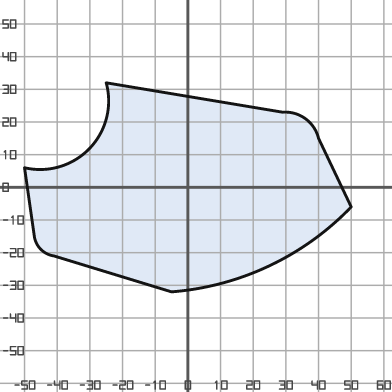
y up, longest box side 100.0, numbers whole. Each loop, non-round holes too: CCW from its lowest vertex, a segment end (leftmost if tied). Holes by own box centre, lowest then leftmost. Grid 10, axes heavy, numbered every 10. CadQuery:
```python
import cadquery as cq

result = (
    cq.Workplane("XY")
    .moveTo(-5.0, -32.0)
    .threePointArc((25.0, -24.0), (50.0, -6.0))
    .lineTo(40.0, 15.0)
    .threePointArc((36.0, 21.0), (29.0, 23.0))
    .lineTo(-25.0, 32.0)
    .threePointArc((-30.0, 12.0), (-50.0, 6.0))
    .lineTo(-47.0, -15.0)
    .threePointArc((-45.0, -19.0), (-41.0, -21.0))
    .close()
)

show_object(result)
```